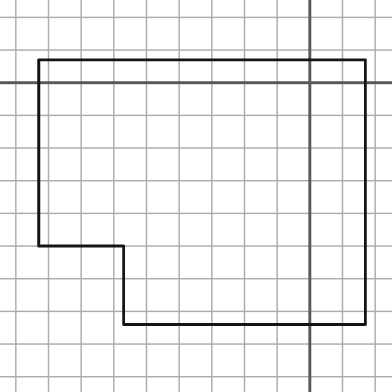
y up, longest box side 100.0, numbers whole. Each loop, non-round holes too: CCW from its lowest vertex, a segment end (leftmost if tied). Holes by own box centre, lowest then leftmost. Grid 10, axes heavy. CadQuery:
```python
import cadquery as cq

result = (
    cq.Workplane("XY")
    .moveTo(-57.0, -74.0)
    .lineTo(17.0, -74.0)
    .lineTo(17.0, 7.0)
    .lineTo(-83.0, 7.0)
    .lineTo(-83.0, -50.0)
    .lineTo(-57.0, -50.0)
    .close()
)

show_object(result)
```